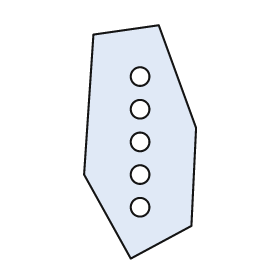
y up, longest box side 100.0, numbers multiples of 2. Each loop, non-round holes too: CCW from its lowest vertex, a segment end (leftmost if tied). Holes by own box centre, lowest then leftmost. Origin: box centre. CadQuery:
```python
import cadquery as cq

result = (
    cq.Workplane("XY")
    .moveTo(-4.0, -50.0)
    .lineTo(22.0, -36.0)
    .lineTo(24.0, 6.0)
    .lineTo(8.0, 50.0)
    .lineTo(-20.0, 46.0)
    .lineTo(-24.0, -14.0)
    .close()
    .moveTo(0.0, -28.0)
    .circle(4.0)
    .moveTo(0.0, -14.0)
    .circle(4.0)
    .moveTo(0.0, 0.0)
    .circle(4.0)
    .moveTo(0.0, 14.0)
    .circle(4.0)
    .moveTo(0.0, 28.0)
    .circle(4.0)
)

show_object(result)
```